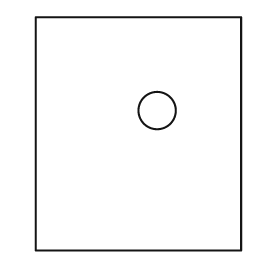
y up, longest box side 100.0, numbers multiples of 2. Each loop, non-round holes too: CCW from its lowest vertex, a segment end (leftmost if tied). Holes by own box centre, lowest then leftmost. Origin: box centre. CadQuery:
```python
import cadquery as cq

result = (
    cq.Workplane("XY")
    .moveTo(-44.0, -50.0)
    .lineTo(44.0, -50.0)
    .lineTo(44.0, 50.0)
    .lineTo(-44.0, 50.0)
    .close()
    .moveTo(8.0, 10.0)
    .circle(8.0)
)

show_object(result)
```